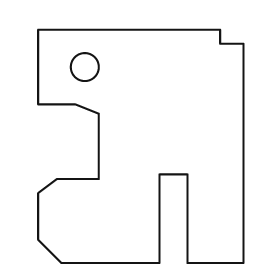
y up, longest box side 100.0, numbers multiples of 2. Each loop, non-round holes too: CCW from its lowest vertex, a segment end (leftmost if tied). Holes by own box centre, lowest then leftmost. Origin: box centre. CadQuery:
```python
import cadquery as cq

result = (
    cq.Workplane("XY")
    .moveTo(-34.0, -50.0)
    .lineTo(8.0, -50.0)
    .lineTo(8.0, -12.0)
    .lineTo(20.0, -12.0)
    .lineTo(20.0, -50.0)
    .lineTo(44.0, -50.0)
    .lineTo(44.0, 44.0)
    .lineTo(34.0, 44.0)
    .lineTo(34.0, 50.0)
    .lineTo(-44.0, 50.0)
    .lineTo(-44.0, 18.0)
    .lineTo(-28.0, 18.0)
    .lineTo(-18.0, 14.0)
    .lineTo(-18.0, -14.0)
    .lineTo(-36.0, -14.0)
    .lineTo(-44.0, -20.0)
    .lineTo(-44.0, -40.0)
    .close()
    .moveTo(-24.0, 34.0)
    .circle(6.0)
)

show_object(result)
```